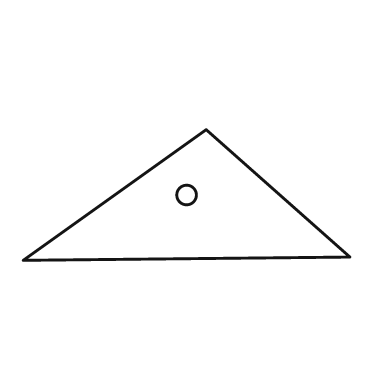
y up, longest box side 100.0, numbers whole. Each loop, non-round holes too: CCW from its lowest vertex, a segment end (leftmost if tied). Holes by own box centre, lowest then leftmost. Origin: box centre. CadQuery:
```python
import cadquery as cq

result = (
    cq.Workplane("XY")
    .moveTo(-50.0, -20.0)
    .lineTo(50.0, -19.0)
    .lineTo(6.0, 20.0)
    .close()
    .moveTo(0.0, 0.0)
    .circle(3.0)
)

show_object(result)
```